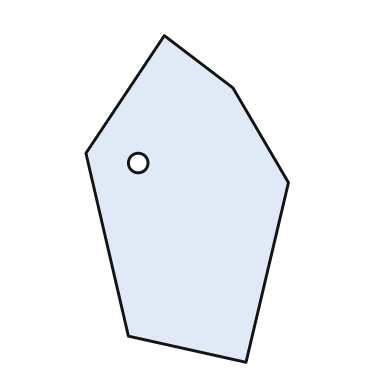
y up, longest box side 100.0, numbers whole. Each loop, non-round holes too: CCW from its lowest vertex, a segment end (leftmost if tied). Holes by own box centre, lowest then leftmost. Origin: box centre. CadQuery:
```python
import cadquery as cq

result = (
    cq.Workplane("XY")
    .moveTo(18.0, -50.0)
    .lineTo(31.0, 5.0)
    .lineTo(14.0, 34.0)
    .lineTo(-7.0, 50.0)
    .lineTo(-31.0, 14.0)
    .lineTo(-18.0, -42.0)
    .close()
    .moveTo(-15.0, 11.0)
    .circle(3.0)
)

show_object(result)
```